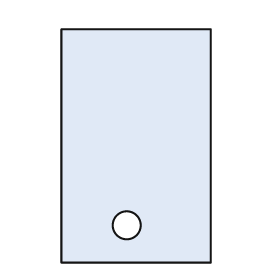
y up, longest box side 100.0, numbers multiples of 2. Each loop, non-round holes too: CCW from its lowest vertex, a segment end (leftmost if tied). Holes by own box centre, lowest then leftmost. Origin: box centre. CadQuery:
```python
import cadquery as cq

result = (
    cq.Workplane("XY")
    .moveTo(-32.0, -50.0)
    .lineTo(32.0, -50.0)
    .lineTo(32.0, 50.0)
    .lineTo(-32.0, 50.0)
    .close()
    .moveTo(-4.0, -34.0)
    .circle(6.0)
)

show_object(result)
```